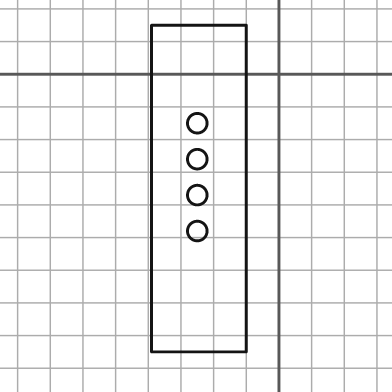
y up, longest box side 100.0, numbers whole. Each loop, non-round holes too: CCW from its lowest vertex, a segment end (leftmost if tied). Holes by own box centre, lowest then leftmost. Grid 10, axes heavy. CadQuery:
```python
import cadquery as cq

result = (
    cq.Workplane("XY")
    .moveTo(-39.0, -85.0)
    .lineTo(-10.0, -85.0)
    .lineTo(-10.0, 15.0)
    .lineTo(-39.0, 15.0)
    .close()
    .moveTo(-25.0, -48.0)
    .circle(3.0)
    .moveTo(-25.0, -37.0)
    .circle(3.0)
    .moveTo(-25.0, -26.0)
    .circle(3.0)
    .moveTo(-25.0, -15.0)
    .circle(3.0)
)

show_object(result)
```